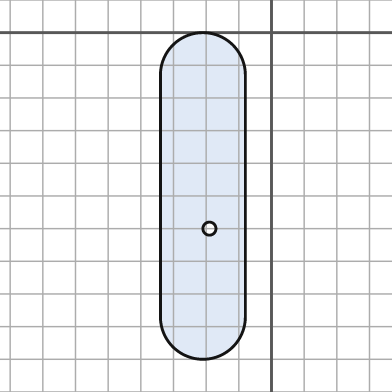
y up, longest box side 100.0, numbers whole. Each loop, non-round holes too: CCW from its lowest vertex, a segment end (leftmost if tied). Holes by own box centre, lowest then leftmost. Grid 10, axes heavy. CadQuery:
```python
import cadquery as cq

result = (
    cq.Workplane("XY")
    .moveTo(-34.0, -87.0)
    .threePointArc((-21.0, -100.0), (-8.0, -87.0))
    .lineTo(-8.0, -13.0)
    .threePointArc((-21.0, 0.0), (-34.0, -13.0))
    .close()
    .moveTo(-19.0, -60.0)
    .circle(2.0)
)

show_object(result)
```